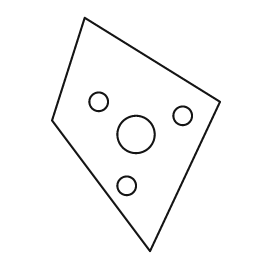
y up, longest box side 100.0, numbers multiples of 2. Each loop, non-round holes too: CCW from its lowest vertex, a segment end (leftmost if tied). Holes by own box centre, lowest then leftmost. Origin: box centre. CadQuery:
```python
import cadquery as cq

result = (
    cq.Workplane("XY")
    .moveTo(6.0, -50.0)
    .lineTo(36.0, 14.0)
    .lineTo(-22.0, 50.0)
    .lineTo(-36.0, 6.0)
    .close()
    .moveTo(-4.0, -22.0)
    .circle(4.0)
    .moveTo(0.0, 0.0)
    .circle(8.0)
    .moveTo(20.0, 8.0)
    .circle(4.0)
    .moveTo(-16.0, 14.0)
    .circle(4.0)
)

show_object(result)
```